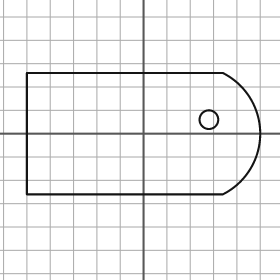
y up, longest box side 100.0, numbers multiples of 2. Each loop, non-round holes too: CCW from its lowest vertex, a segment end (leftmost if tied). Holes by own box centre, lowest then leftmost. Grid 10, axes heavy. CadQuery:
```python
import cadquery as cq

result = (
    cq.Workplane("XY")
    .moveTo(-50.0, -26.0)
    .lineTo(34.0, -26.0)
    .threePointArc((50.0, 0.0), (34.0, 26.0))
    .lineTo(-50.0, 26.0)
    .close()
    .moveTo(28.0, 6.0)
    .circle(4.0)
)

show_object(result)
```